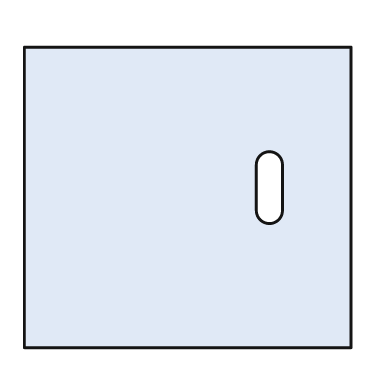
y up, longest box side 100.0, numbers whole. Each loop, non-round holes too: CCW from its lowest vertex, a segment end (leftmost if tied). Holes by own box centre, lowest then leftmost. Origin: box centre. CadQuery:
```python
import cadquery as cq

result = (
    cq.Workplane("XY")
    .moveTo(-50.0, -46.0)
    .lineTo(50.0, -46.0)
    .lineTo(50.0, 46.0)
    .lineTo(-50.0, 46.0)
    .close()
    .moveTo(21.0, -4.0)
    .threePointArc((25.0, -8.0), (29.0, -4.0))
    .lineTo(29.0, 10.0)
    .threePointArc((25.0, 14.0), (21.0, 10.0))
    .close()
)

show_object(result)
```